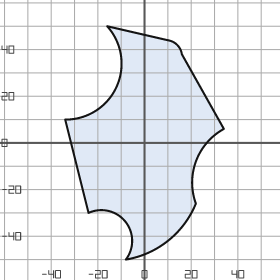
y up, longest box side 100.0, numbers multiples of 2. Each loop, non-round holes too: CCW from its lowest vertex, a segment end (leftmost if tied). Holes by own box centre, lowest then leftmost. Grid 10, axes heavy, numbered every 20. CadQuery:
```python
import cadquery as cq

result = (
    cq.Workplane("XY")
    .moveTo(-8.0, -50.0)
    .threePointArc((10.0, -42.0), (22.0, -26.0))
    .threePointArc((22.0, -8.0), (34.0, 6.0))
    .lineTo(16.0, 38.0)
    .threePointArc((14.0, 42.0), (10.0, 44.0))
    .lineTo(-16.0, 50.0)
    .threePointArc((-12.0, 24.0), (-34.0, 10.0))
    .lineTo(-24.0, -30.0)
    .threePointArc((-8.0, -34.0), (-8.0, -50.0))
    .close()
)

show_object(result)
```